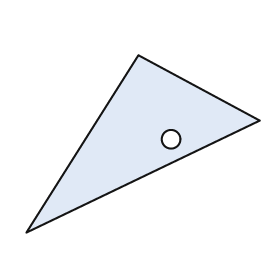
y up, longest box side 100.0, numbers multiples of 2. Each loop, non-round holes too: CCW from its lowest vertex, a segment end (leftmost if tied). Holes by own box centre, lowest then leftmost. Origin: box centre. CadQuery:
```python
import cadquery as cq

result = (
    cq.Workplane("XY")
    .moveTo(-50.0, -38.0)
    .lineTo(50.0, 10.0)
    .lineTo(-2.0, 38.0)
    .close()
    .moveTo(12.0, 2.0)
    .circle(4.0)
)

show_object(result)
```